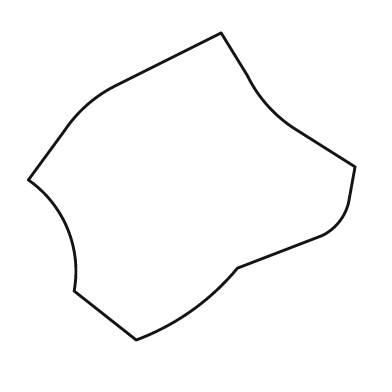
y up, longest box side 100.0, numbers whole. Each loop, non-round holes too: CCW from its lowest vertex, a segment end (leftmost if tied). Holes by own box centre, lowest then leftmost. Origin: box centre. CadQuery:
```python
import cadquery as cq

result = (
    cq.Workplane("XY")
    .moveTo(-17.0, -47.0)
    .threePointArc((0.0, -38.0), (14.0, -25.0))
    .lineTo(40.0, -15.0)
    .threePointArc((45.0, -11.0), (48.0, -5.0))
    .lineTo(50.0, 6.0)
    .lineTo(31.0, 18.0)
    .threePointArc((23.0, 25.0), (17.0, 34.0))
    .lineTo(9.0, 47.0)
    .lineTo(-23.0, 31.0)
    .threePointArc((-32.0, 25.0), (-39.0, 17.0))
    .lineTo(-50.0, 2.0)
    .threePointArc((-38.0, -13.0), (-36.0, -32.0))
    .close()
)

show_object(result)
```